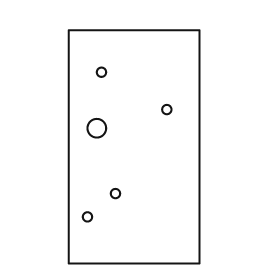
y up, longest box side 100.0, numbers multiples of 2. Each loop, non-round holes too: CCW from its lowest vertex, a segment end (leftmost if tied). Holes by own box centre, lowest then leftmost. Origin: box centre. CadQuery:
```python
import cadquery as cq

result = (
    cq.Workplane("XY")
    .moveTo(-28.0, -50.0)
    .lineTo(28.0, -50.0)
    .lineTo(28.0, 50.0)
    .lineTo(-28.0, 50.0)
    .close()
    .moveTo(-20.0, -30.0)
    .circle(2.0)
    .moveTo(-8.0, -20.0)
    .circle(2.0)
    .moveTo(-16.0, 8.0)
    .circle(4.0)
    .moveTo(14.0, 16.0)
    .circle(2.0)
    .moveTo(-14.0, 32.0)
    .circle(2.0)
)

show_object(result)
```